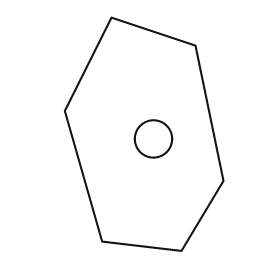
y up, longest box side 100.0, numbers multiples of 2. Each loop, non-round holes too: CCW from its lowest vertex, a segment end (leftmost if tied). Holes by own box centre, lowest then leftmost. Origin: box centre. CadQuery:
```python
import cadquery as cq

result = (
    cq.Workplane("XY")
    .moveTo(16.0, -50.0)
    .lineTo(34.0, -20.0)
    .lineTo(22.0, 38.0)
    .lineTo(-14.0, 50.0)
    .lineTo(-34.0, 10.0)
    .lineTo(-18.0, -46.0)
    .close()
    .moveTo(4.0, -2.0)
    .circle(8.0)
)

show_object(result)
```